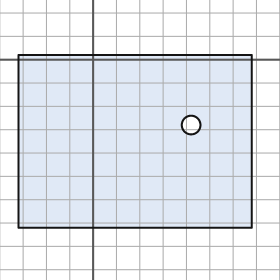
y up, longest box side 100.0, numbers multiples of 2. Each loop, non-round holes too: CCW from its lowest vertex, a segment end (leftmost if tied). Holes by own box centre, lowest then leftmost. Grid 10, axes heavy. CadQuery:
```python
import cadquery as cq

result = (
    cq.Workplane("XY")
    .moveTo(-32.0, -72.0)
    .lineTo(68.0, -72.0)
    .lineTo(68.0, 2.0)
    .lineTo(-32.0, 2.0)
    .close()
    .moveTo(42.0, -28.0)
    .circle(4.0)
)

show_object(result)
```